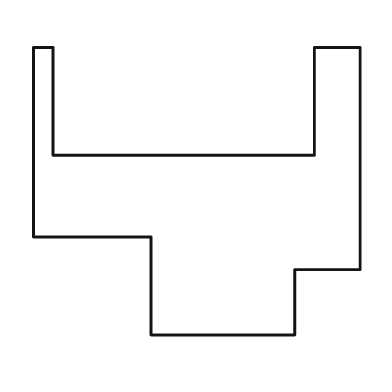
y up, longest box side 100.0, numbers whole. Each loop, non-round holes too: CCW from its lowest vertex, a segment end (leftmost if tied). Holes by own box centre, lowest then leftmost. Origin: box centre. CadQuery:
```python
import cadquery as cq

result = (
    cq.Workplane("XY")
    .moveTo(-14.0, -44.0)
    .lineTo(30.0, -44.0)
    .lineTo(30.0, -24.0)
    .lineTo(50.0, -24.0)
    .lineTo(50.0, 44.0)
    .lineTo(36.0, 44.0)
    .lineTo(36.0, 11.0)
    .lineTo(-44.0, 11.0)
    .lineTo(-44.0, 44.0)
    .lineTo(-50.0, 44.0)
    .lineTo(-50.0, -14.0)
    .lineTo(-14.0, -14.0)
    .close()
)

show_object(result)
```